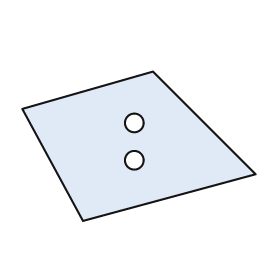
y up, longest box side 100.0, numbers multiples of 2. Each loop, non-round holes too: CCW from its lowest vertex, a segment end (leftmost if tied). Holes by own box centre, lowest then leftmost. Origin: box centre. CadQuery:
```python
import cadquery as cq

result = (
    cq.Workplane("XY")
    .moveTo(-24.0, -32.0)
    .lineTo(50.0, -12.0)
    .lineTo(6.0, 32.0)
    .lineTo(-50.0, 16.0)
    .close()
    .moveTo(-2.0, -6.0)
    .circle(4.0)
    .moveTo(-2.0, 10.0)
    .circle(4.0)
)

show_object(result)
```